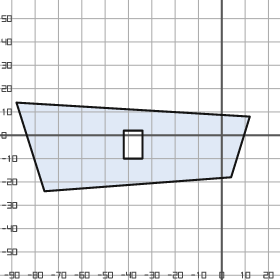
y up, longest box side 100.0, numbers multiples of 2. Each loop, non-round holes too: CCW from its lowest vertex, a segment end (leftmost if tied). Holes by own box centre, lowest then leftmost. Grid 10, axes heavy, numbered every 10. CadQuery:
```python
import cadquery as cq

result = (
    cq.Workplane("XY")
    .moveTo(-76.0, -24.0)
    .lineTo(4.0, -18.0)
    .lineTo(12.0, 8.0)
    .lineTo(-88.0, 14.0)
    .close()
    .moveTo(-42.0, -10.0)
    .lineTo(-34.0, -10.0)
    .lineTo(-34.0, 2.0)
    .lineTo(-42.0, 2.0)
    .close()
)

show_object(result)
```